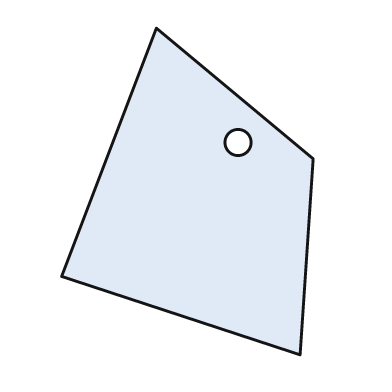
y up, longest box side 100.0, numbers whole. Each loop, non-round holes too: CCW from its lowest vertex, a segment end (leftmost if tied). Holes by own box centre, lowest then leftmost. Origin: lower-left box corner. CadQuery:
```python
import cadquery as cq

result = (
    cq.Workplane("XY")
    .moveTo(73.0, 0.0)
    .lineTo(77.0, 60.0)
    .lineTo(29.0, 100.0)
    .lineTo(0.0, 24.0)
    .close()
    .moveTo(54.0, 65.0)
    .circle(4.0)
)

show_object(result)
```